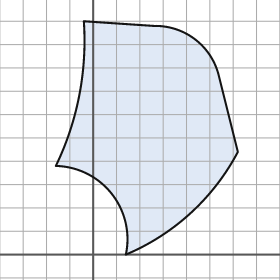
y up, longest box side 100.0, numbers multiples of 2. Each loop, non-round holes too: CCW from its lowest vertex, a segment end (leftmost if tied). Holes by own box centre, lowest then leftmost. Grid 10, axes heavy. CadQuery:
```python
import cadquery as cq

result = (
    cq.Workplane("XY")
    .moveTo(14.0, 0.0)
    .threePointArc((42.0, 18.0), (62.0, 44.0))
    .lineTo(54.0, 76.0)
    .threePointArc((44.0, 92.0), (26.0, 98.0))
    .lineTo(-4.0, 100.0)
    .threePointArc((-6.0, 68.0), (-16.0, 38.0))
    .threePointArc((8.0, 26.0), (14.0, 0.0))
    .close()
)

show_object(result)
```